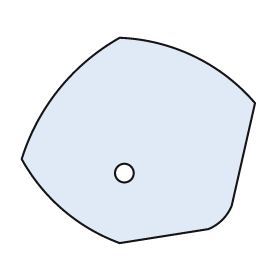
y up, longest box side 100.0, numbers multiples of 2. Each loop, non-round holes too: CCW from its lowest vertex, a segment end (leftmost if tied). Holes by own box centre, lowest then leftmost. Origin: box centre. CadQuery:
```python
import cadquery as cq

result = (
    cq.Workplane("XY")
    .moveTo(-8.0, -44.0)
    .lineTo(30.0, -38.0)
    .threePointArc((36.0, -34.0), (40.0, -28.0))
    .lineTo(50.0, 16.0)
    .threePointArc((24.0, 36.0), (-8.0, 44.0))
    .threePointArc((-34.0, 22.0), (-50.0, -8.0))
    .threePointArc((-32.0, -30.0), (-8.0, -44.0))
    .close()
    .moveTo(-6.0, -14.0)
    .circle(4.0)
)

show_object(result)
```